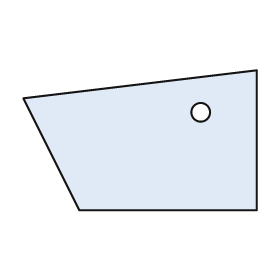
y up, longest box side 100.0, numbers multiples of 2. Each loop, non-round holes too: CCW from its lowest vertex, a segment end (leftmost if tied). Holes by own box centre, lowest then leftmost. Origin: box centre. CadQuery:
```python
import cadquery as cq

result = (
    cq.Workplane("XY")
    .moveTo(-26.0, -30.0)
    .lineTo(50.0, -30.0)
    .lineTo(50.0, 30.0)
    .lineTo(-50.0, 18.0)
    .close()
    .moveTo(26.0, 12.0)
    .circle(4.0)
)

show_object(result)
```